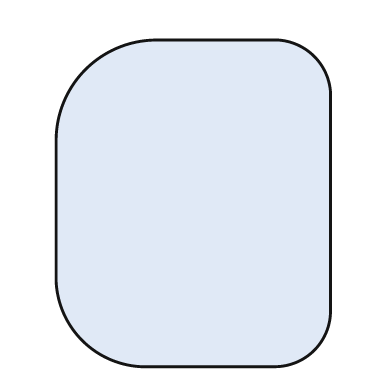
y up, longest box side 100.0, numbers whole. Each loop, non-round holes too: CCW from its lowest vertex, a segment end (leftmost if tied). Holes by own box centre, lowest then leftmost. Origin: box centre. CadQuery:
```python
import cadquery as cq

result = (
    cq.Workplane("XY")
    .moveTo(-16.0, -50.0)
    .lineTo(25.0, -50.0)
    .threePointArc((37.0, -45.0), (42.0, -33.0))
    .lineTo(42.0, 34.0)
    .threePointArc((37.0, 45.0), (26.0, 50.0))
    .lineTo(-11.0, 50.0)
    .threePointArc((-33.0, 41.0), (-42.0, 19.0))
    .lineTo(-42.0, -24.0)
    .threePointArc((-34.0, -42.0), (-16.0, -50.0))
    .close()
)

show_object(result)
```